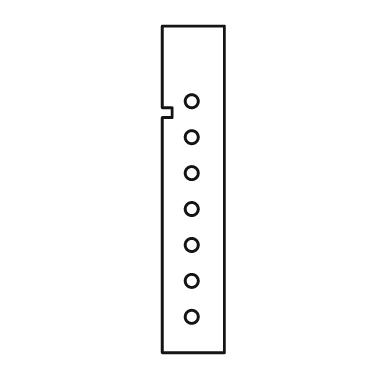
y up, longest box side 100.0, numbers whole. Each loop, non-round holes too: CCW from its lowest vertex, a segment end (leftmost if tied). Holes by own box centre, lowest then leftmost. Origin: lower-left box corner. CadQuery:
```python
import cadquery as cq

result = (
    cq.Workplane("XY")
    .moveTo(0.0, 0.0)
    .lineTo(19.0, 0.0)
    .lineTo(19.0, 100.0)
    .lineTo(0.0, 100.0)
    .lineTo(0.0, 75.0)
    .lineTo(3.0, 75.0)
    .lineTo(3.0, 72.0)
    .lineTo(0.0, 72.0)
    .close()
    .moveTo(9.0, 11.0)
    .circle(2.0)
    .moveTo(9.0, 22.0)
    .circle(2.0)
    .moveTo(9.0, 33.0)
    .circle(2.0)
    .moveTo(9.0, 44.0)
    .circle(2.0)
    .moveTo(9.0, 55.0)
    .circle(2.0)
    .moveTo(9.0, 66.0)
    .circle(2.0)
    .moveTo(9.0, 77.0)
    .circle(2.0)
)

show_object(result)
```